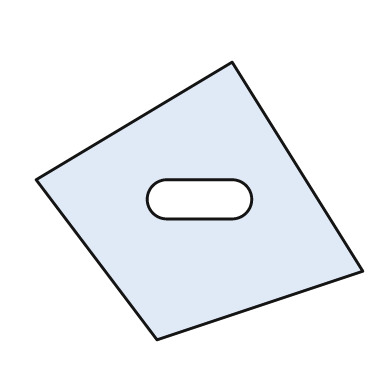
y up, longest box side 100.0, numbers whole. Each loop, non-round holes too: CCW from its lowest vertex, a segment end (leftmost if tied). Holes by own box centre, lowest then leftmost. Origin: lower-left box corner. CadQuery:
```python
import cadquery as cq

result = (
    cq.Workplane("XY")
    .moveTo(37.0, 0.0)
    .lineTo(100.0, 21.0)
    .lineTo(60.0, 85.0)
    .lineTo(0.0, 49.0)
    .close()
    .moveTo(40.0, 37.0)
    .lineTo(60.0, 37.0)
    .threePointArc((66.0, 43.0), (60.0, 49.0))
    .lineTo(40.0, 49.0)
    .threePointArc((34.0, 43.0), (40.0, 37.0))
    .close()
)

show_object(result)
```